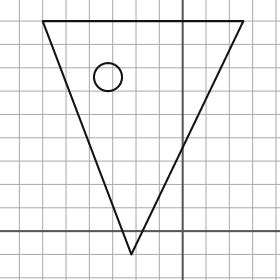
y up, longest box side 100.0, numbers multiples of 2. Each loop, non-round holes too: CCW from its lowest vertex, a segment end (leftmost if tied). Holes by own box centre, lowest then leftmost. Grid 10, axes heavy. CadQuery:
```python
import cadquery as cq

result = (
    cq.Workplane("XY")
    .moveTo(-22.0, -10.0)
    .lineTo(26.0, 90.0)
    .lineTo(-60.0, 90.0)
    .close()
    .moveTo(-32.0, 66.0)
    .circle(6.0)
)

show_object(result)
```